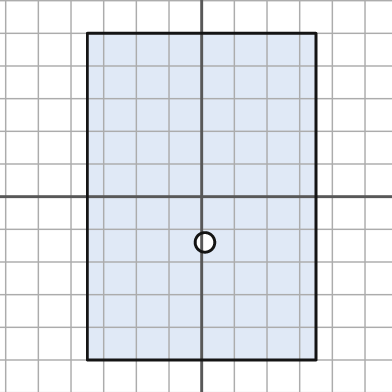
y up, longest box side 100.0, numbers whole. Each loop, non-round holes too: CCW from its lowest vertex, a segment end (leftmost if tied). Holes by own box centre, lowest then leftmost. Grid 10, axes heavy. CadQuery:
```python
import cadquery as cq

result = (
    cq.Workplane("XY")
    .moveTo(-35.0, -50.0)
    .lineTo(35.0, -50.0)
    .lineTo(35.0, 50.0)
    .lineTo(-35.0, 50.0)
    .close()
    .moveTo(1.0, -14.0)
    .circle(3.0)
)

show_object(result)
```